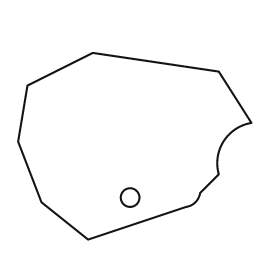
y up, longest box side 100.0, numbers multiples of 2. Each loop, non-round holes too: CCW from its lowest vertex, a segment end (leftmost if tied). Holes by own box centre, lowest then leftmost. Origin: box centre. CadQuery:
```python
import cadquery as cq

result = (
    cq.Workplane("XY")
    .moveTo(-20.0, -40.0)
    .lineTo(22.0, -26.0)
    .threePointArc((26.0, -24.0), (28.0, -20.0))
    .lineTo(36.0, -12.0)
    .threePointArc((38.0, 2.0), (50.0, 10.0))
    .lineTo(36.0, 32.0)
    .lineTo(-18.0, 40.0)
    .lineTo(-46.0, 26.0)
    .lineTo(-50.0, 2.0)
    .lineTo(-40.0, -24.0)
    .close()
    .moveTo(-2.0, -22.0)
    .circle(4.0)
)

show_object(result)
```